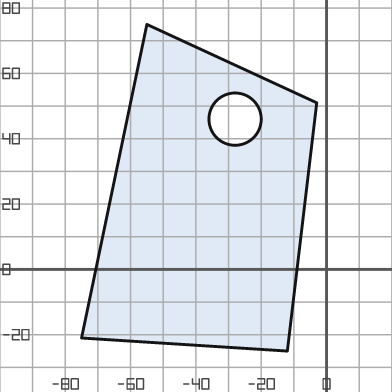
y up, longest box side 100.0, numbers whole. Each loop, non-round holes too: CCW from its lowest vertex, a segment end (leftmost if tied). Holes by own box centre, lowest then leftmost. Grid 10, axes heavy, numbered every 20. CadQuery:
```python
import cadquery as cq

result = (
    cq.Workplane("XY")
    .moveTo(-12.0, -25.0)
    .lineTo(-3.0, 51.0)
    .lineTo(-55.0, 75.0)
    .lineTo(-75.0, -21.0)
    .close()
    .moveTo(-28.0, 46.0)
    .circle(8.0)
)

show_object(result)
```